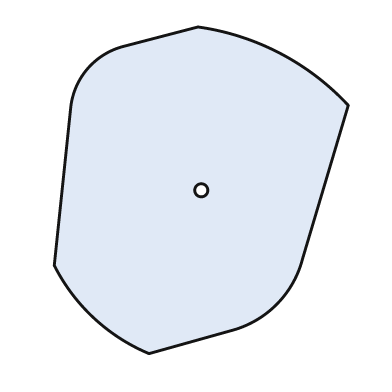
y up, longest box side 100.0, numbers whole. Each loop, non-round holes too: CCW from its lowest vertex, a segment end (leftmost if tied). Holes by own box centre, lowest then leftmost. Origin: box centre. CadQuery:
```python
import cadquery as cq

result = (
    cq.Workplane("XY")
    .moveTo(-16.0, -50.0)
    .lineTo(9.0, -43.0)
    .threePointArc((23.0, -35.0), (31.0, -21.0))
    .lineTo(45.0, 26.0)
    .threePointArc((24.0, 42.0), (-1.0, 50.0))
    .lineTo(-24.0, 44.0)
    .threePointArc((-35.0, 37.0), (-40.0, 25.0))
    .lineTo(-45.0, -23.0)
    .threePointArc((-33.0, -39.0), (-16.0, -50.0))
    .close()
    .moveTo(0.0, 0.0)
    .circle(2.0)
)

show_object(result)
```